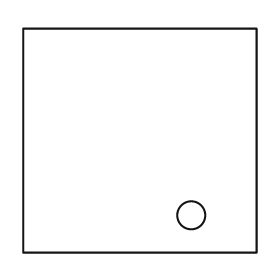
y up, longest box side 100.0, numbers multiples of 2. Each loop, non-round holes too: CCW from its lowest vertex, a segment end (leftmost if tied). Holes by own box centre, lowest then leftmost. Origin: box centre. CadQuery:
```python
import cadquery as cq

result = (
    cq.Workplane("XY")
    .moveTo(-50.0, -48.0)
    .lineTo(50.0, -48.0)
    .lineTo(50.0, 48.0)
    .lineTo(-50.0, 48.0)
    .close()
    .moveTo(22.0, -32.0)
    .circle(6.0)
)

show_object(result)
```